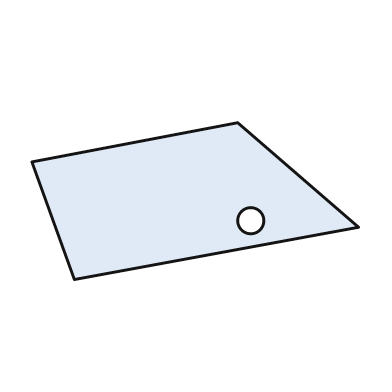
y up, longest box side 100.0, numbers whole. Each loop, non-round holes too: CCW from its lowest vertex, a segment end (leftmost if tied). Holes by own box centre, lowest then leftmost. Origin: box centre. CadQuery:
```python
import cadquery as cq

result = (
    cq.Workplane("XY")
    .moveTo(-37.0, -24.0)
    .lineTo(50.0, -8.0)
    .lineTo(13.0, 24.0)
    .lineTo(-50.0, 12.0)
    .close()
    .moveTo(17.0, -6.0)
    .circle(4.0)
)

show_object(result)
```